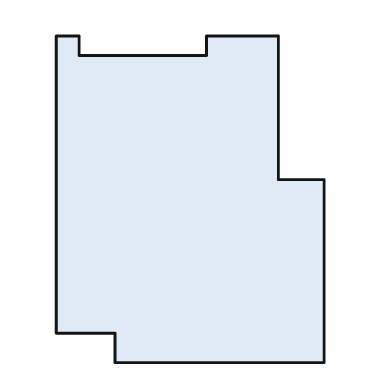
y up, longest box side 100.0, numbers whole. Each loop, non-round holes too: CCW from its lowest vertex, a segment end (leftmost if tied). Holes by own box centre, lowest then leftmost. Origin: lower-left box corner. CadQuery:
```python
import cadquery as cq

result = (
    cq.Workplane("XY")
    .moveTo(18.0, 0.0)
    .lineTo(82.0, 0.0)
    .lineTo(82.0, 56.0)
    .lineTo(68.0, 56.0)
    .lineTo(68.0, 100.0)
    .lineTo(46.0, 100.0)
    .lineTo(46.0, 94.0)
    .lineTo(7.0, 94.0)
    .lineTo(7.0, 100.0)
    .lineTo(0.0, 100.0)
    .lineTo(0.0, 9.0)
    .lineTo(18.0, 9.0)
    .close()
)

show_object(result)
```